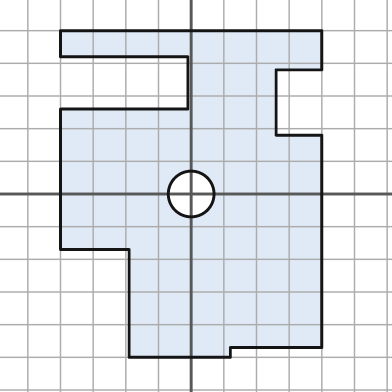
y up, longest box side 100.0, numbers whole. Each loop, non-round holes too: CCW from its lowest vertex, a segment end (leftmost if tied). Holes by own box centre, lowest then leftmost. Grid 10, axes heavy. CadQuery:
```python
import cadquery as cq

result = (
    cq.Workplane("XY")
    .moveTo(-19.0, -50.0)
    .lineTo(12.0, -50.0)
    .lineTo(12.0, -47.0)
    .lineTo(40.0, -47.0)
    .lineTo(40.0, 18.0)
    .lineTo(26.0, 18.0)
    .lineTo(26.0, 38.0)
    .lineTo(40.0, 38.0)
    .lineTo(40.0, 50.0)
    .lineTo(-40.0, 50.0)
    .lineTo(-40.0, 42.0)
    .lineTo(-1.0, 42.0)
    .lineTo(-1.0, 26.0)
    .lineTo(-40.0, 26.0)
    .lineTo(-40.0, -17.0)
    .lineTo(-19.0, -17.0)
    .close()
    .moveTo(0.0, 0.0)
    .circle(7.0)
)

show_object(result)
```